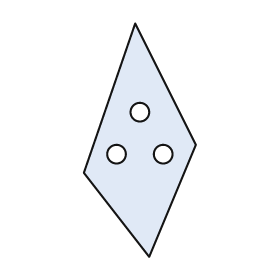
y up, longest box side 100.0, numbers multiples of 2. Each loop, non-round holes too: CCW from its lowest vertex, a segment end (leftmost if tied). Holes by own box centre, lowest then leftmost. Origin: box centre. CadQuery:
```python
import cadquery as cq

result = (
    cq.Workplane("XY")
    .moveTo(4.0, -50.0)
    .lineTo(24.0, -2.0)
    .lineTo(-2.0, 50.0)
    .lineTo(-24.0, -14.0)
    .close()
    .moveTo(-10.0, -6.0)
    .circle(4.0)
    .moveTo(10.0, -6.0)
    .circle(4.0)
    .moveTo(0.0, 12.0)
    .circle(4.0)
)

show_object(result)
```